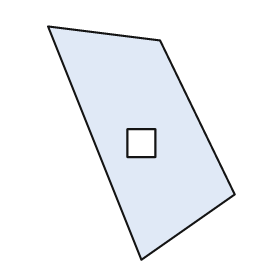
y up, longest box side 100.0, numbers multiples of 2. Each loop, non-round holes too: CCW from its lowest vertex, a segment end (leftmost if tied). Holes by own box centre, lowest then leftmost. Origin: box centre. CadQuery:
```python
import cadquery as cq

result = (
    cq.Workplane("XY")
    .moveTo(0.0, -50.0)
    .lineTo(40.0, -22.0)
    .lineTo(8.0, 44.0)
    .lineTo(-40.0, 50.0)
    .close()
    .moveTo(-6.0, -6.0)
    .lineTo(6.0, -6.0)
    .lineTo(6.0, 6.0)
    .lineTo(-6.0, 6.0)
    .close()
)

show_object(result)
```